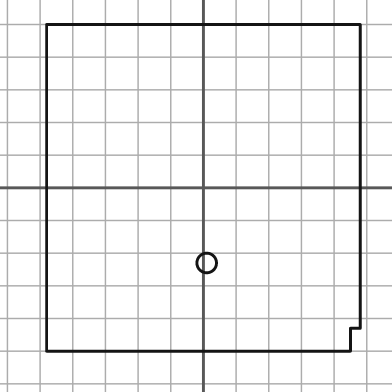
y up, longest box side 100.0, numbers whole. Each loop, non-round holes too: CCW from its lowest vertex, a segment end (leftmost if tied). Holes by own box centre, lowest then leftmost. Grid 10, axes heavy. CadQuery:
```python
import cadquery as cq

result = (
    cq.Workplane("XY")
    .moveTo(-48.0, -50.0)
    .lineTo(45.0, -50.0)
    .lineTo(45.0, -43.0)
    .lineTo(48.0, -43.0)
    .lineTo(48.0, 50.0)
    .lineTo(-48.0, 50.0)
    .close()
    .moveTo(1.0, -23.0)
    .circle(3.0)
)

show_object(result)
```